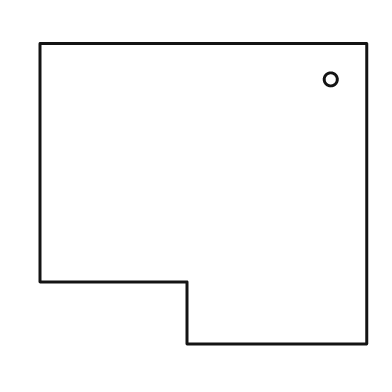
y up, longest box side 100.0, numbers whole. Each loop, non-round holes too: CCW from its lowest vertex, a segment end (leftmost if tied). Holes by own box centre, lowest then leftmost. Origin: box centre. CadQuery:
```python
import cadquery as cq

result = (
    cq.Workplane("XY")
    .moveTo(-5.0, -46.0)
    .lineTo(50.0, -46.0)
    .lineTo(50.0, 46.0)
    .lineTo(-50.0, 46.0)
    .lineTo(-50.0, -27.0)
    .lineTo(-5.0, -27.0)
    .close()
    .moveTo(39.0, 35.0)
    .circle(2.0)
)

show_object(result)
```